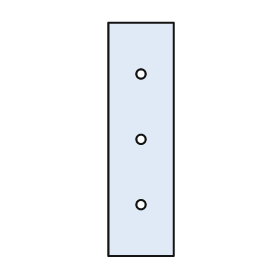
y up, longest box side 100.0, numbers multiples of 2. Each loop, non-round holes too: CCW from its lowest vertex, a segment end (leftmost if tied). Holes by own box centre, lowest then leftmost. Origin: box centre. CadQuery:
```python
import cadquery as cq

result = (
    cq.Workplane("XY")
    .moveTo(-14.0, -50.0)
    .lineTo(14.0, -50.0)
    .lineTo(14.0, 50.0)
    .lineTo(-14.0, 50.0)
    .close()
    .moveTo(0.0, -28.0)
    .circle(2.0)
    .moveTo(0.0, 0.0)
    .circle(2.0)
    .moveTo(0.0, 28.0)
    .circle(2.0)
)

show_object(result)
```